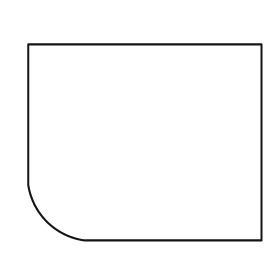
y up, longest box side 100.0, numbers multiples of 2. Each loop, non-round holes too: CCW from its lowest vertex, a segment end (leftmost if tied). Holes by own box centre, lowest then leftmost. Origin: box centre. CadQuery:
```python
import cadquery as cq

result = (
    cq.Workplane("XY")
    .moveTo(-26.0, -42.0)
    .lineTo(50.0, -42.0)
    .lineTo(50.0, 42.0)
    .lineTo(-50.0, 42.0)
    .lineTo(-50.0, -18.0)
    .threePointArc((-42.0, -34.0), (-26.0, -42.0))
    .close()
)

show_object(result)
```